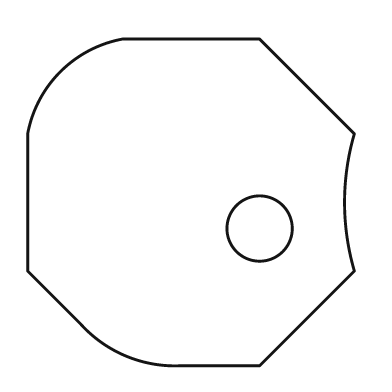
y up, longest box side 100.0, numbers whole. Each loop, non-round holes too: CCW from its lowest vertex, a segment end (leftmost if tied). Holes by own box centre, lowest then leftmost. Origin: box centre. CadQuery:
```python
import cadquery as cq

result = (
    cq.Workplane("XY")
    .moveTo(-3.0, -50.0)
    .lineTo(21.0, -50.0)
    .lineTo(50.0, -21.0)
    .threePointArc((47.0, 0.0), (50.0, 21.0))
    .lineTo(21.0, 50.0)
    .lineTo(-21.0, 50.0)
    .threePointArc((-40.0, 40.0), (-50.0, 21.0))
    .lineTo(-50.0, -21.0)
    .lineTo(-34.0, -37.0)
    .threePointArc((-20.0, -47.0), (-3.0, -50.0))
    .close()
    .moveTo(21.0, -8.0)
    .circle(10.0)
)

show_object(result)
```